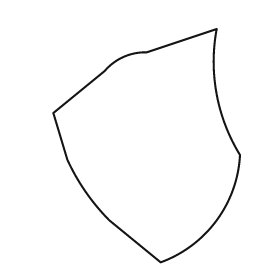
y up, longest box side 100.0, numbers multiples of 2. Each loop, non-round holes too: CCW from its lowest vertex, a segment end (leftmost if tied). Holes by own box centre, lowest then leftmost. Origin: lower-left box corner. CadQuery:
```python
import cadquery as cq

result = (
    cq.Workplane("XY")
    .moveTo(46.0, 0.0)
    .threePointArc((70.0, 18.0), (80.0, 46.0))
    .threePointArc((70.0, 72.0), (70.0, 100.0))
    .lineTo(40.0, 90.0)
    .threePointArc((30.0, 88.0), (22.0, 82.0))
    .lineTo(0.0, 64.0)
    .lineTo(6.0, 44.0)
    .threePointArc((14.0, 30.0), (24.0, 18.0))
    .close()
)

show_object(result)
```